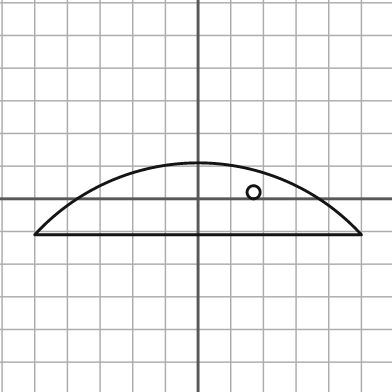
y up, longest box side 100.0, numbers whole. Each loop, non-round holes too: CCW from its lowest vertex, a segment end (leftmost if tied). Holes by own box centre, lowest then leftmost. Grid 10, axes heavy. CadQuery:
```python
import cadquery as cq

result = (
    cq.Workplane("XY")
    .moveTo(-50.0, -11.0)
    .lineTo(50.0, -11.0)
    .threePointArc((0.0, 11.0), (-50.0, -11.0))
    .close()
    .moveTo(17.0, 2.0)
    .circle(2.0)
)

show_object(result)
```